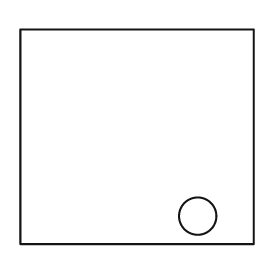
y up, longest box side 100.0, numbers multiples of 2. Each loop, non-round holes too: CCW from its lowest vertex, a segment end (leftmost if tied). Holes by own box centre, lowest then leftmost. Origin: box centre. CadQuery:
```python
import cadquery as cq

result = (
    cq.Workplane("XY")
    .moveTo(-50.0, -46.0)
    .lineTo(50.0, -46.0)
    .lineTo(50.0, 46.0)
    .lineTo(-50.0, 46.0)
    .close()
    .moveTo(26.0, -34.0)
    .circle(8.0)
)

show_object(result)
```